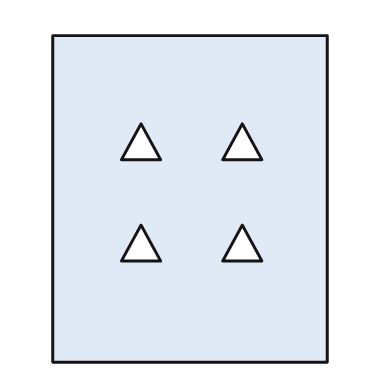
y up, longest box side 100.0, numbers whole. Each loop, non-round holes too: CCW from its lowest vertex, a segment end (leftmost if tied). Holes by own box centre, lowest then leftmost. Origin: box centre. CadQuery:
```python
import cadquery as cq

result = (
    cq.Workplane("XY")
    .moveTo(-42.0, -50.0)
    .lineTo(42.0, -50.0)
    .lineTo(42.0, 50.0)
    .lineTo(-42.0, 50.0)
    .close()
    .moveTo(-21.0, -19.0)
    .lineTo(-9.0, -19.0)
    .lineTo(-15.0, -8.0)
    .close()
    .moveTo(10.0, -19.0)
    .lineTo(22.0, -19.0)
    .lineTo(16.0, -8.0)
    .close()
    .moveTo(-21.0, 12.0)
    .lineTo(-9.0, 12.0)
    .lineTo(-15.0, 23.0)
    .close()
    .moveTo(10.0, 12.0)
    .lineTo(22.0, 12.0)
    .lineTo(16.0, 23.0)
    .close()
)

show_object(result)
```